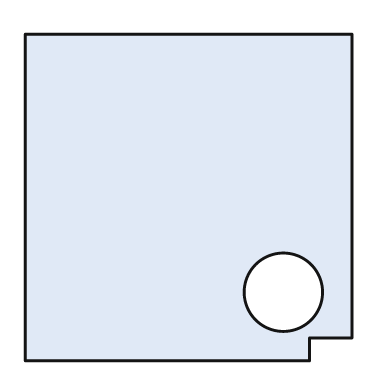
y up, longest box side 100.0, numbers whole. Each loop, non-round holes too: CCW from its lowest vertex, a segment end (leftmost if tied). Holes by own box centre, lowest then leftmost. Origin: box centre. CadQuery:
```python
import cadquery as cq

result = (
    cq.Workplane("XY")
    .moveTo(-50.0, -50.0)
    .lineTo(37.0, -50.0)
    .lineTo(37.0, -43.0)
    .lineTo(50.0, -43.0)
    .lineTo(50.0, 50.0)
    .lineTo(-50.0, 50.0)
    .close()
    .moveTo(29.0, -29.0)
    .circle(12.0)
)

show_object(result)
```